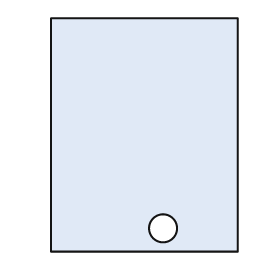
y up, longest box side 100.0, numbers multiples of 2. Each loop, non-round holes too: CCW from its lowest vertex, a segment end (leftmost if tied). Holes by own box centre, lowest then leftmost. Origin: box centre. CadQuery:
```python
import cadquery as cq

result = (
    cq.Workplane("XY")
    .moveTo(-40.0, -50.0)
    .lineTo(40.0, -50.0)
    .lineTo(40.0, 50.0)
    .lineTo(-40.0, 50.0)
    .close()
    .moveTo(8.0, -40.0)
    .circle(6.0)
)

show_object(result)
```